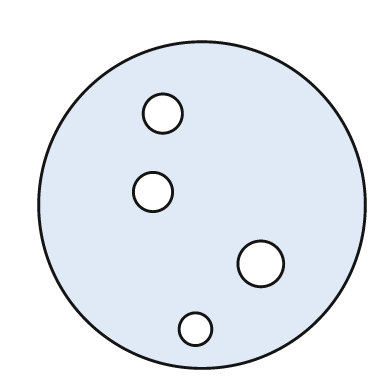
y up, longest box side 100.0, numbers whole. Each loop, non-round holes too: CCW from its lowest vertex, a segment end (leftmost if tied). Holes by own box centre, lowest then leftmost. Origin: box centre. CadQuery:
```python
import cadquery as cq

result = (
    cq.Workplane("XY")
    .moveTo(0.0, 0.0)
    .circle(50.0)
    .moveTo(-2.0, -38.0)
    .circle(5.0)
    .moveTo(18.0, -18.0)
    .circle(7.0)
    .moveTo(-15.0, 4.0)
    .circle(6.0)
    .moveTo(-12.0, 28.0)
    .circle(6.0)
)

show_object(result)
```